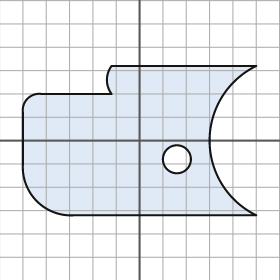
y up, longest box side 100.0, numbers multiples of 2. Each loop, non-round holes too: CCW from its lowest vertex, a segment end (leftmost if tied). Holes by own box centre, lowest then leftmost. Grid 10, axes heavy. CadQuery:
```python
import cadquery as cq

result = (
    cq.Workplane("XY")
    .moveTo(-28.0, -32.0)
    .lineTo(50.0, -32.0)
    .threePointArc((30.0, 0.0), (50.0, 32.0))
    .lineTo(-12.0, 32.0)
    .threePointArc((-14.0, 26.0), (-12.0, 20.0))
    .lineTo(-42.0, 20.0)
    .threePointArc((-48.0, 18.0), (-50.0, 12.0))
    .lineTo(-50.0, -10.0)
    .threePointArc((-44.0, -26.0), (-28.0, -32.0))
    .close()
    .moveTo(16.0, -8.0)
    .circle(6.0)
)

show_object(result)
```